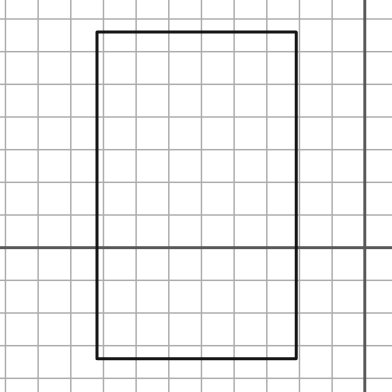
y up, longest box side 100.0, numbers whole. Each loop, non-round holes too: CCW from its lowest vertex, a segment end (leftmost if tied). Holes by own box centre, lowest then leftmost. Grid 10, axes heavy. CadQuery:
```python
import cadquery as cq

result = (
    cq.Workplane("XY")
    .moveTo(-82.0, -34.0)
    .lineTo(-21.0, -34.0)
    .lineTo(-21.0, 66.0)
    .lineTo(-82.0, 66.0)
    .close()
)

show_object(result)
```